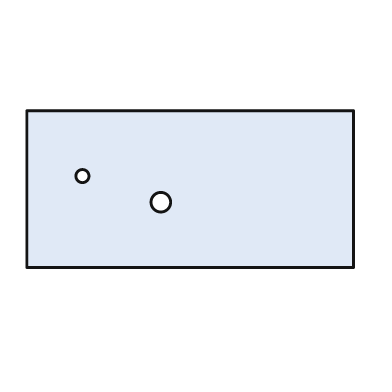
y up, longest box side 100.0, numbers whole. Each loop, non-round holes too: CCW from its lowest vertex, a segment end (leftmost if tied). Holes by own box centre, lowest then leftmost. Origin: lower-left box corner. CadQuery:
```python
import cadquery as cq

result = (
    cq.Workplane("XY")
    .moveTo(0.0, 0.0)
    .lineTo(100.0, 0.0)
    .lineTo(100.0, 48.0)
    .lineTo(0.0, 48.0)
    .close()
    .moveTo(41.0, 20.0)
    .circle(3.0)
    .moveTo(17.0, 28.0)
    .circle(2.0)
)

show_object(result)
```